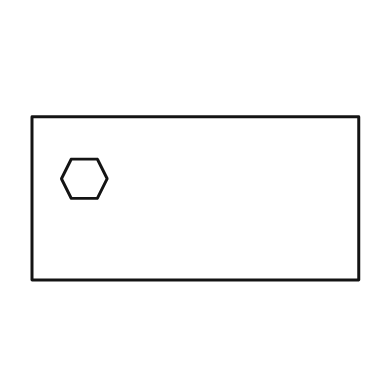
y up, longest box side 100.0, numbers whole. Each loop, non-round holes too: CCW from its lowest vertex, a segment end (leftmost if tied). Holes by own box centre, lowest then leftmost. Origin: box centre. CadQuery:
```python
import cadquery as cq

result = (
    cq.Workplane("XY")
    .moveTo(-50.0, -25.0)
    .lineTo(50.0, -25.0)
    .lineTo(50.0, 25.0)
    .lineTo(-50.0, 25.0)
    .close()
    .moveTo(-38.0, 0.0)
    .lineTo(-30.0, 0.0)
    .lineTo(-27.0, 6.0)
    .lineTo(-30.0, 12.0)
    .lineTo(-38.0, 12.0)
    .lineTo(-41.0, 6.0)
    .close()
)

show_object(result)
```